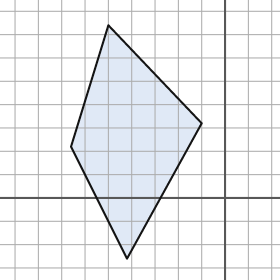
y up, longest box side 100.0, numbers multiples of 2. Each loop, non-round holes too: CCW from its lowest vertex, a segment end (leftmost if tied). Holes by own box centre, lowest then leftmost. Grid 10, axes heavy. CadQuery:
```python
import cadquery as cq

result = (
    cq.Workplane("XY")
    .moveTo(-42.0, -26.0)
    .lineTo(-10.0, 32.0)
    .lineTo(-50.0, 74.0)
    .lineTo(-66.0, 22.0)
    .close()
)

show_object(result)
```